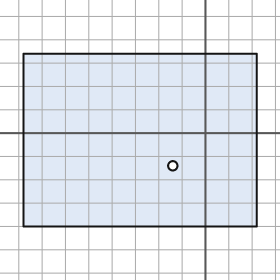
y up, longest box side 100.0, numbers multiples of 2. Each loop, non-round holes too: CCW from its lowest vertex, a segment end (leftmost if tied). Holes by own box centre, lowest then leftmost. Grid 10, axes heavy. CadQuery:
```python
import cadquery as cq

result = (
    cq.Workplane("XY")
    .moveTo(-78.0, -40.0)
    .lineTo(22.0, -40.0)
    .lineTo(22.0, 34.0)
    .lineTo(-78.0, 34.0)
    .close()
    .moveTo(-14.0, -14.0)
    .circle(2.0)
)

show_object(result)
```